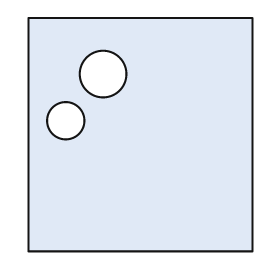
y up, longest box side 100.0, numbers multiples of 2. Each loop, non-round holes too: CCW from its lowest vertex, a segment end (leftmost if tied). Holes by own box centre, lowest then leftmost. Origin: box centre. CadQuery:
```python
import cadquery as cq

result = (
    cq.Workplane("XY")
    .moveTo(-48.0, -50.0)
    .lineTo(48.0, -50.0)
    .lineTo(48.0, 50.0)
    .lineTo(-48.0, 50.0)
    .close()
    .moveTo(-32.0, 6.0)
    .circle(8.0)
    .moveTo(-16.0, 26.0)
    .circle(10.0)
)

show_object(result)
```